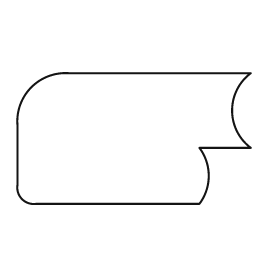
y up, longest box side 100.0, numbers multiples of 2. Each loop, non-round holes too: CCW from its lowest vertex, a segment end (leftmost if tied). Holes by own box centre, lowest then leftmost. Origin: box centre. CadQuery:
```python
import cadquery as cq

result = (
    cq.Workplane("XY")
    .moveTo(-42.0, -28.0)
    .lineTo(28.0, -28.0)
    .threePointArc((32.0, -16.0), (28.0, -4.0))
    .lineTo(50.0, -4.0)
    .threePointArc((42.0, 12.0), (50.0, 28.0))
    .lineTo(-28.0, 28.0)
    .threePointArc((-44.0, 22.0), (-50.0, 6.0))
    .lineTo(-50.0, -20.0)
    .threePointArc((-48.0, -26.0), (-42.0, -28.0))
    .close()
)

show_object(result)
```